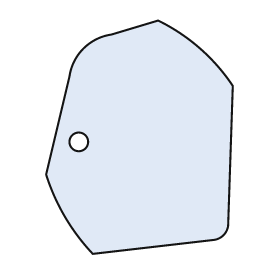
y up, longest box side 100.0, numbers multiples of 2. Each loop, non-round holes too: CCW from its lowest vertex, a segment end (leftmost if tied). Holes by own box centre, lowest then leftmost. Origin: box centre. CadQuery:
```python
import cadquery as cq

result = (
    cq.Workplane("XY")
    .moveTo(-20.0, -50.0)
    .lineTo(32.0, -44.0)
    .threePointArc((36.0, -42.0), (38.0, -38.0))
    .lineTo(40.0, 22.0)
    .threePointArc((26.0, 38.0), (8.0, 50.0))
    .lineTo(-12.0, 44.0)
    .threePointArc((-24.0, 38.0), (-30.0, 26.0))
    .lineTo(-40.0, -16.0)
    .threePointArc((-32.0, -34.0), (-20.0, -50.0))
    .close()
    .moveTo(-26.0, -2.0)
    .circle(4.0)
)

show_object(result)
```